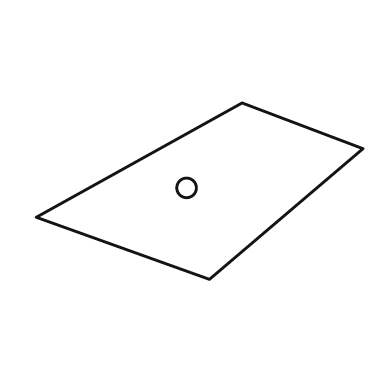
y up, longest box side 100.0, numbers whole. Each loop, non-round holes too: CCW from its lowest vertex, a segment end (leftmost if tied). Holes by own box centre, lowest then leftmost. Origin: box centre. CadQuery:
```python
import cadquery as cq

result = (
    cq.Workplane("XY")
    .moveTo(3.0, -27.0)
    .lineTo(50.0, 13.0)
    .lineTo(13.0, 27.0)
    .lineTo(-50.0, -8.0)
    .close()
    .moveTo(-4.0, 1.0)
    .circle(3.0)
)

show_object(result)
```